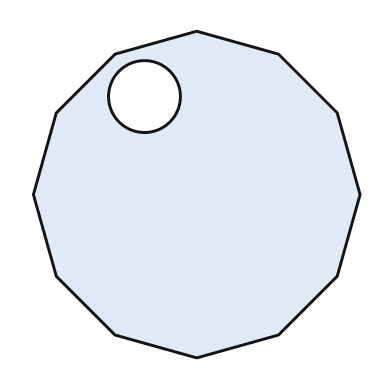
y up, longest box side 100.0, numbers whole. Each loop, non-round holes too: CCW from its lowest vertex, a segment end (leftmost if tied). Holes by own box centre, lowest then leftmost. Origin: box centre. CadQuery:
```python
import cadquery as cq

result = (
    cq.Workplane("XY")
    .moveTo(0.0, -50.0)
    .lineTo(25.0, -43.0)
    .lineTo(43.0, -25.0)
    .lineTo(50.0, 0.0)
    .lineTo(43.0, 25.0)
    .lineTo(25.0, 43.0)
    .lineTo(0.0, 50.0)
    .lineTo(-25.0, 43.0)
    .lineTo(-43.0, 25.0)
    .lineTo(-50.0, 0.0)
    .lineTo(-43.0, -25.0)
    .lineTo(-25.0, -43.0)
    .close()
    .moveTo(-16.0, 30.0)
    .circle(11.0)
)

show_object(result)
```